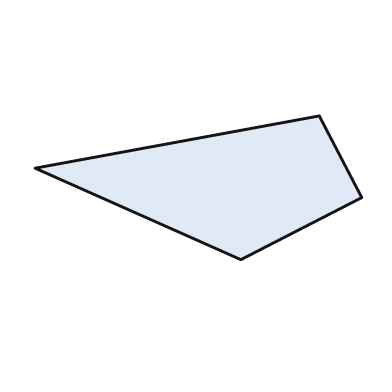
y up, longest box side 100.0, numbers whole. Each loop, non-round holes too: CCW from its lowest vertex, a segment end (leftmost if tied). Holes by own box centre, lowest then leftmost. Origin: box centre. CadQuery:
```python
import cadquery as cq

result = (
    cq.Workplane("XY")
    .moveTo(13.0, -22.0)
    .lineTo(50.0, -3.0)
    .lineTo(37.0, 22.0)
    .lineTo(-50.0, 6.0)
    .close()
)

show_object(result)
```